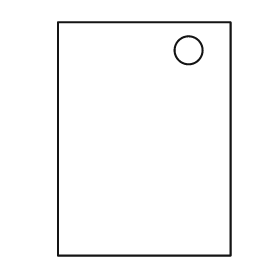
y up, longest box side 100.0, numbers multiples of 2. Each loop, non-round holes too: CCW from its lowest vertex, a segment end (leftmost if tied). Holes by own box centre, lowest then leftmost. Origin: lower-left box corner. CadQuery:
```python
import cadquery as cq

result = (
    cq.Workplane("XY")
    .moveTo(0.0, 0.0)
    .lineTo(74.0, 0.0)
    .lineTo(74.0, 100.0)
    .lineTo(0.0, 100.0)
    .close()
    .moveTo(56.0, 88.0)
    .circle(6.0)
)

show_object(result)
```